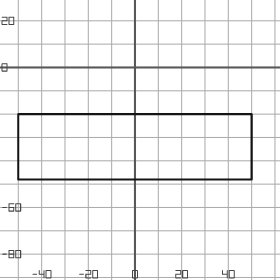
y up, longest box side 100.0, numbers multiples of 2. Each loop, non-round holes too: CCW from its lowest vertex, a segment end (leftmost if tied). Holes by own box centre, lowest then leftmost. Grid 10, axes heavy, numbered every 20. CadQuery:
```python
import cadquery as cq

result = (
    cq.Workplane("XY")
    .moveTo(-50.0, -48.0)
    .lineTo(50.0, -48.0)
    .lineTo(50.0, -20.0)
    .lineTo(-50.0, -20.0)
    .close()
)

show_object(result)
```